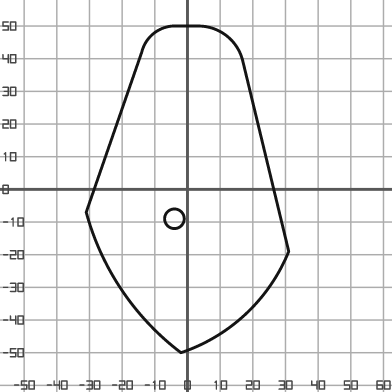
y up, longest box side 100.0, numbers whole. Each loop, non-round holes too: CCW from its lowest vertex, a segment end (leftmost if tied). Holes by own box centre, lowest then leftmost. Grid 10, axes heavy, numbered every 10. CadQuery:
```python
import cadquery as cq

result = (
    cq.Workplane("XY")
    .moveTo(-2.0, -50.0)
    .threePointArc((18.0, -38.0), (31.0, -19.0))
    .lineTo(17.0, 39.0)
    .threePointArc((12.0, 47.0), (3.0, 50.0))
    .lineTo(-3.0, 50.0)
    .threePointArc((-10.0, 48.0), (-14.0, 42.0))
    .lineTo(-31.0, -7.0)
    .threePointArc((-20.0, -31.0), (-2.0, -50.0))
    .close()
    .moveTo(-4.0, -9.0)
    .circle(3.0)
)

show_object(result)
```